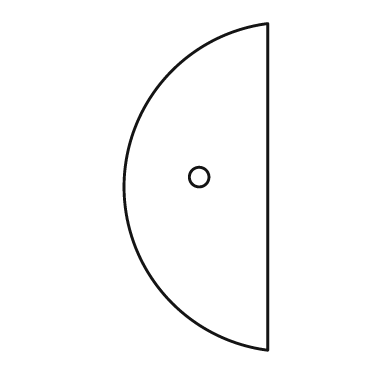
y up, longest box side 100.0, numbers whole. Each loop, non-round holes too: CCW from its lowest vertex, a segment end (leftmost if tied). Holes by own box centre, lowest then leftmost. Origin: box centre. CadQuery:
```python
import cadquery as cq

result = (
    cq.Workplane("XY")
    .moveTo(22.0, -50.0)
    .lineTo(22.0, 50.0)
    .threePointArc((-22.0, 0.0), (22.0, -50.0))
    .close()
    .moveTo(1.0, 3.0)
    .circle(3.0)
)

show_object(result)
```